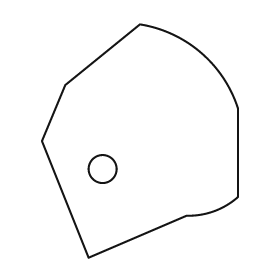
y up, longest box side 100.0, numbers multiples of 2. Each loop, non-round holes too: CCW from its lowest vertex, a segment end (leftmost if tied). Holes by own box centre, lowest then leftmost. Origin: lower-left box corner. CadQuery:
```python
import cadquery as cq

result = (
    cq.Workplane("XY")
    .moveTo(20.0, 0.0)
    .lineTo(62.0, 18.0)
    .threePointArc((74.0, 20.0), (84.0, 26.0))
    .lineTo(84.0, 64.0)
    .threePointArc((68.0, 88.0), (42.0, 100.0))
    .lineTo(10.0, 74.0)
    .lineTo(0.0, 50.0)
    .close()
    .moveTo(26.0, 38.0)
    .circle(6.0)
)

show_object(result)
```